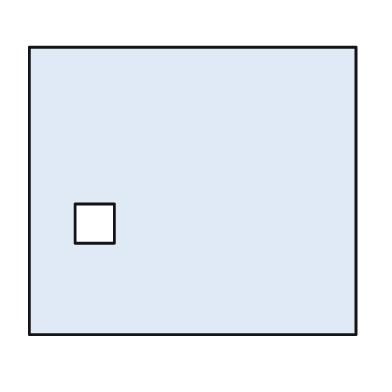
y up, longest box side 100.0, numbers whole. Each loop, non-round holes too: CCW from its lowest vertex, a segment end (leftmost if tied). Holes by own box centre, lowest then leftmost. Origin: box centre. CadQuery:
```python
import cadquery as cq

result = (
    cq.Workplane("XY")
    .moveTo(-50.0, -44.0)
    .lineTo(50.0, -44.0)
    .lineTo(50.0, 44.0)
    .lineTo(-50.0, 44.0)
    .close()
    .moveTo(-36.0, -16.0)
    .lineTo(-24.0, -16.0)
    .lineTo(-24.0, -4.0)
    .lineTo(-36.0, -4.0)
    .close()
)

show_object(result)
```